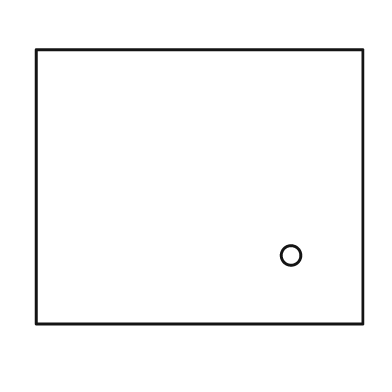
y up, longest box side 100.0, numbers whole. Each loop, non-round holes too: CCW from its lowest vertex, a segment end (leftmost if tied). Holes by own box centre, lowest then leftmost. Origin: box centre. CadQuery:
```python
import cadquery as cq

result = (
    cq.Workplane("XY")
    .moveTo(-50.0, -42.0)
    .lineTo(50.0, -42.0)
    .lineTo(50.0, 42.0)
    .lineTo(-50.0, 42.0)
    .close()
    .moveTo(28.0, -21.0)
    .circle(3.0)
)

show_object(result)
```